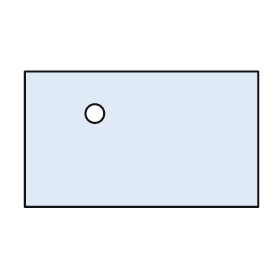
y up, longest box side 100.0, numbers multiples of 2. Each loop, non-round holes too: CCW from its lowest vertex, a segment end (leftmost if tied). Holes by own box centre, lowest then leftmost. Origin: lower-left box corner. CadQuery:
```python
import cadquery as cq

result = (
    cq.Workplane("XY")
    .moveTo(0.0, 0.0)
    .lineTo(100.0, 0.0)
    .lineTo(100.0, 58.0)
    .lineTo(0.0, 58.0)
    .close()
    .moveTo(30.0, 40.0)
    .circle(4.0)
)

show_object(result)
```